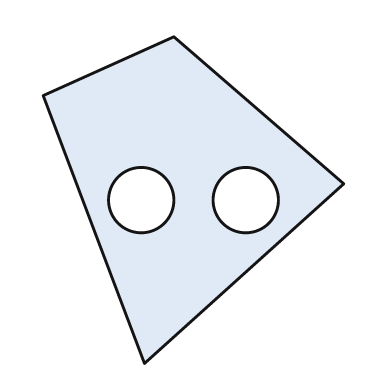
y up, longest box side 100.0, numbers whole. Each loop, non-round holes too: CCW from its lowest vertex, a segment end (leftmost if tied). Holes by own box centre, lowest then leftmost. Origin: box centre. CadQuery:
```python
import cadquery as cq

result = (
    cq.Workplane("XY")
    .moveTo(-15.0, -50.0)
    .lineTo(46.0, 5.0)
    .lineTo(-6.0, 50.0)
    .lineTo(-46.0, 32.0)
    .close()
    .moveTo(-16.0, 0.0)
    .circle(10.0)
    .moveTo(16.0, 0.0)
    .circle(10.0)
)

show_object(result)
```